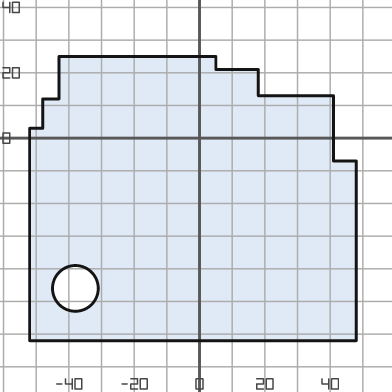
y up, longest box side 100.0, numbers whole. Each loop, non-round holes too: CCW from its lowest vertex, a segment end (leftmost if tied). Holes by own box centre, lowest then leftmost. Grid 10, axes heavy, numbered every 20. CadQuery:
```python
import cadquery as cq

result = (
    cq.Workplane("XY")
    .moveTo(-52.0, -62.0)
    .lineTo(48.0, -62.0)
    .lineTo(48.0, -7.0)
    .lineTo(41.0, -7.0)
    .lineTo(41.0, 13.0)
    .lineTo(18.0, 13.0)
    .lineTo(18.0, 21.0)
    .lineTo(5.0, 21.0)
    .lineTo(5.0, 25.0)
    .lineTo(-43.0, 25.0)
    .lineTo(-43.0, 12.0)
    .lineTo(-48.0, 12.0)
    .lineTo(-48.0, 3.0)
    .lineTo(-52.0, 3.0)
    .close()
    .moveTo(-38.0, -46.0)
    .circle(7.0)
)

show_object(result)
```